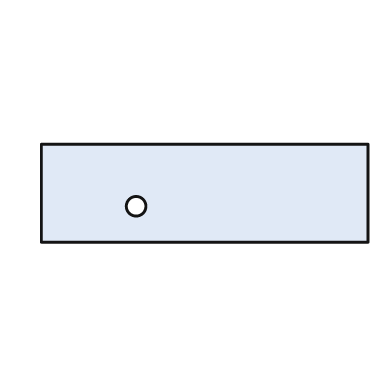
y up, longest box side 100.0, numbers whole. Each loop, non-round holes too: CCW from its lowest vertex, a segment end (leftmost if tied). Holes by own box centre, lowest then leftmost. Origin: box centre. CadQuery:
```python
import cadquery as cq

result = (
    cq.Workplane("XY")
    .moveTo(-50.0, -15.0)
    .lineTo(50.0, -15.0)
    .lineTo(50.0, 15.0)
    .lineTo(-50.0, 15.0)
    .close()
    .moveTo(-21.0, -4.0)
    .circle(3.0)
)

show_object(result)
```